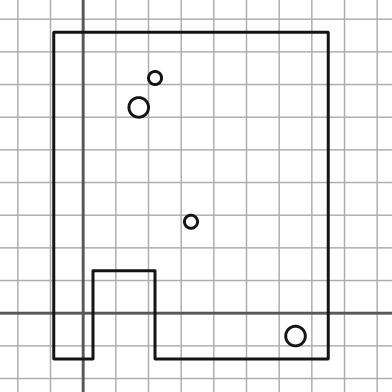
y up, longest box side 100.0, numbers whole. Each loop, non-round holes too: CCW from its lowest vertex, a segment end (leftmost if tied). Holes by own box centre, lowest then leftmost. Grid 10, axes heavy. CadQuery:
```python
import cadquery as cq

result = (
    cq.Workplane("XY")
    .moveTo(-9.0, -14.0)
    .lineTo(3.0, -14.0)
    .lineTo(3.0, 13.0)
    .lineTo(22.0, 13.0)
    .lineTo(22.0, -14.0)
    .lineTo(75.0, -14.0)
    .lineTo(75.0, 86.0)
    .lineTo(-9.0, 86.0)
    .close()
    .moveTo(65.0, -7.0)
    .circle(3.0)
    .moveTo(33.0, 28.0)
    .circle(2.0)
    .moveTo(17.0, 63.0)
    .circle(3.0)
    .moveTo(22.0, 72.0)
    .circle(2.0)
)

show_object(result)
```